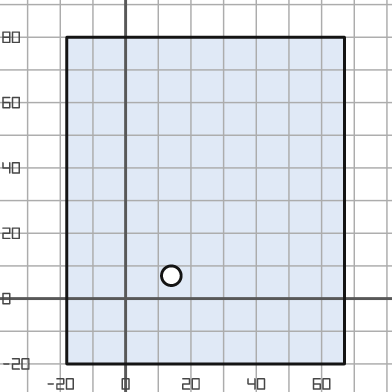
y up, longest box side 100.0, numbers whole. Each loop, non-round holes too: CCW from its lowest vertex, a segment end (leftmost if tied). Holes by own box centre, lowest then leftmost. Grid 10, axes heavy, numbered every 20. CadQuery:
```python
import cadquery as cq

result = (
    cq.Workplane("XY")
    .moveTo(-18.0, -20.0)
    .lineTo(67.0, -20.0)
    .lineTo(67.0, 80.0)
    .lineTo(-18.0, 80.0)
    .close()
    .moveTo(14.0, 7.0)
    .circle(3.0)
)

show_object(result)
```